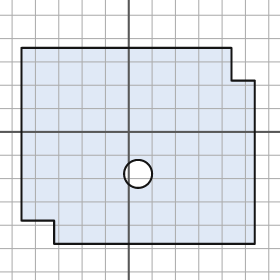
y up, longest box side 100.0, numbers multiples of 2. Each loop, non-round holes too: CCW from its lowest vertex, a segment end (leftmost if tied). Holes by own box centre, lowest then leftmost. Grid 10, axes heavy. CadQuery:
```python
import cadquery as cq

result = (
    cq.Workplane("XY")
    .moveTo(-32.0, -48.0)
    .lineTo(54.0, -48.0)
    .lineTo(54.0, 22.0)
    .lineTo(44.0, 22.0)
    .lineTo(44.0, 36.0)
    .lineTo(-46.0, 36.0)
    .lineTo(-46.0, -38.0)
    .lineTo(-32.0, -38.0)
    .close()
    .moveTo(4.0, -18.0)
    .circle(6.0)
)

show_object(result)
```